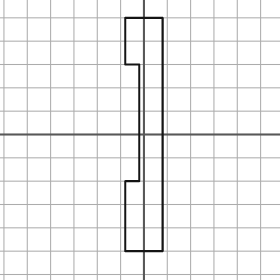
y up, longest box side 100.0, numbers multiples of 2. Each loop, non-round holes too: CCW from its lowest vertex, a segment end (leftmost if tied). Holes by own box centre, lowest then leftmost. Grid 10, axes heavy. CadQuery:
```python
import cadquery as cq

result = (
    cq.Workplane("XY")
    .moveTo(-8.0, -50.0)
    .lineTo(8.0, -50.0)
    .lineTo(8.0, 50.0)
    .lineTo(-8.0, 50.0)
    .lineTo(-8.0, 30.0)
    .lineTo(-2.0, 30.0)
    .lineTo(-2.0, -20.0)
    .lineTo(-8.0, -20.0)
    .close()
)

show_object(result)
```